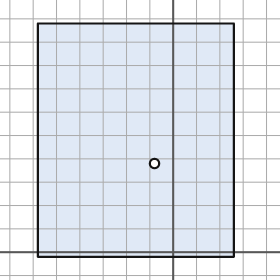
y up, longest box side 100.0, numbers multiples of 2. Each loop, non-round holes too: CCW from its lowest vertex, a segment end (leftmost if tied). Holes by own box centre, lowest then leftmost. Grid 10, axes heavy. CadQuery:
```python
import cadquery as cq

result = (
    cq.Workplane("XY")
    .moveTo(-58.0, -2.0)
    .lineTo(26.0, -2.0)
    .lineTo(26.0, 98.0)
    .lineTo(-58.0, 98.0)
    .close()
    .moveTo(-8.0, 38.0)
    .circle(2.0)
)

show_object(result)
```